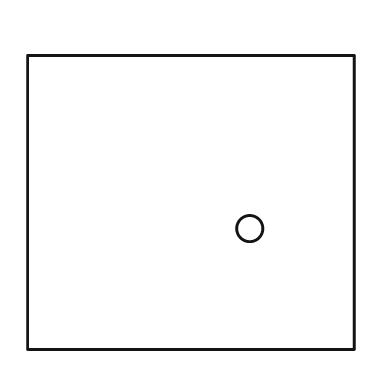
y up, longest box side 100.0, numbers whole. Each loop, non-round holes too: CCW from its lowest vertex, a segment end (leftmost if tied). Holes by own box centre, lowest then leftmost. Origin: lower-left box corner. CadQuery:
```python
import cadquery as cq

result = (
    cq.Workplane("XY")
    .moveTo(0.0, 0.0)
    .lineTo(100.0, 0.0)
    .lineTo(100.0, 90.0)
    .lineTo(0.0, 90.0)
    .close()
    .moveTo(68.0, 37.0)
    .circle(4.0)
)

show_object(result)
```